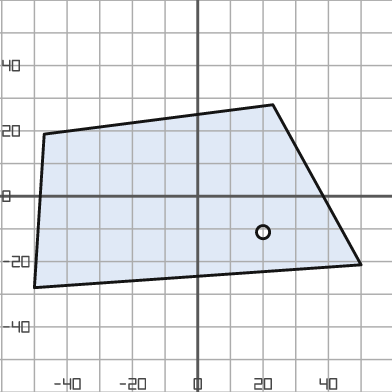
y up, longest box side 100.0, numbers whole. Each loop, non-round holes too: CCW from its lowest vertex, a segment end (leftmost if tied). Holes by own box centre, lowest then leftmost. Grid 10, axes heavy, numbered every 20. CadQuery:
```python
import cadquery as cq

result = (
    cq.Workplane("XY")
    .moveTo(-50.0, -28.0)
    .lineTo(50.0, -21.0)
    .lineTo(23.0, 28.0)
    .lineTo(-47.0, 19.0)
    .close()
    .moveTo(20.0, -11.0)
    .circle(2.0)
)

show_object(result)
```